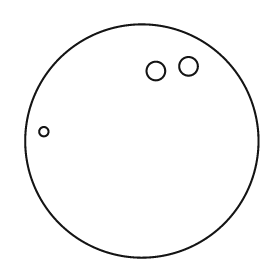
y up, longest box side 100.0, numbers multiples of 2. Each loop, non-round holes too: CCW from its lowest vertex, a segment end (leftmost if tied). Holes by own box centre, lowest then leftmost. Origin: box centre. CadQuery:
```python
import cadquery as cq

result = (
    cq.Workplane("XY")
    .moveTo(0.0, 0.0)
    .circle(50.0)
    .moveTo(-42.0, 4.0)
    .circle(2.0)
    .moveTo(6.0, 30.0)
    .circle(4.0)
    .moveTo(20.0, 32.0)
    .circle(4.0)
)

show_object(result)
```